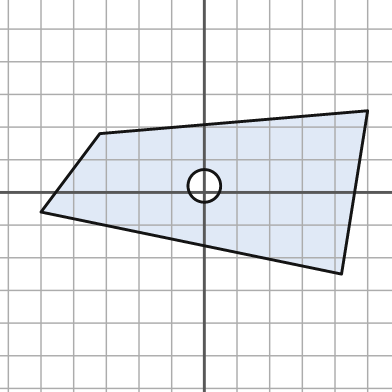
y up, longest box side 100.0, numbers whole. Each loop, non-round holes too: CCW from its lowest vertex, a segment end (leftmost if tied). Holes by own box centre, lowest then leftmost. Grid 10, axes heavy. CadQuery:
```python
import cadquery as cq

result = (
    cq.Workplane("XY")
    .moveTo(42.0, -25.0)
    .lineTo(50.0, 25.0)
    .lineTo(-32.0, 18.0)
    .lineTo(-50.0, -6.0)
    .close()
    .moveTo(0.0, 2.0)
    .circle(5.0)
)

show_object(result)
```